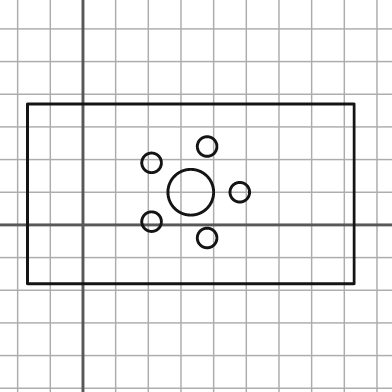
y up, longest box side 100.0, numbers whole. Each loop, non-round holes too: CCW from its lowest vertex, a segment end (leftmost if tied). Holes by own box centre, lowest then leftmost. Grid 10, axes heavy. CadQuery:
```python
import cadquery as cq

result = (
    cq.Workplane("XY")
    .moveTo(-17.0, -18.0)
    .lineTo(83.0, -18.0)
    .lineTo(83.0, 37.0)
    .lineTo(-17.0, 37.0)
    .close()
    .moveTo(38.0, -4.0)
    .circle(3.0)
    .moveTo(21.0, 1.0)
    .circle(3.0)
    .moveTo(33.0, 10.0)
    .circle(7.0)
    .moveTo(48.0, 10.0)
    .circle(3.0)
    .moveTo(21.0, 19.0)
    .circle(3.0)
    .moveTo(38.0, 24.0)
    .circle(3.0)
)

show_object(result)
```